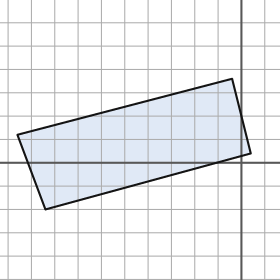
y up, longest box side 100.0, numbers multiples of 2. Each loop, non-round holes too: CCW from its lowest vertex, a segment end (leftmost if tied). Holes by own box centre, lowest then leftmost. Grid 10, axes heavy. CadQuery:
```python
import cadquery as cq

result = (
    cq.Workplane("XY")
    .moveTo(-84.0, -20.0)
    .lineTo(4.0, 4.0)
    .lineTo(-4.0, 36.0)
    .lineTo(-96.0, 12.0)
    .close()
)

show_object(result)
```